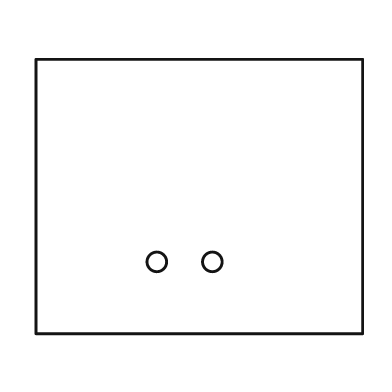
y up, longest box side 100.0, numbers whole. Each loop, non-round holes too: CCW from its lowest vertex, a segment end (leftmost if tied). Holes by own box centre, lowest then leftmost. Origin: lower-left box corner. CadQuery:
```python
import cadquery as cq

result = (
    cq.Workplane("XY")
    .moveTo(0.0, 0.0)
    .lineTo(100.0, 0.0)
    .lineTo(100.0, 84.0)
    .lineTo(0.0, 84.0)
    .close()
    .moveTo(37.0, 22.0)
    .circle(3.0)
    .moveTo(54.0, 22.0)
    .circle(3.0)
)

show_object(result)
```